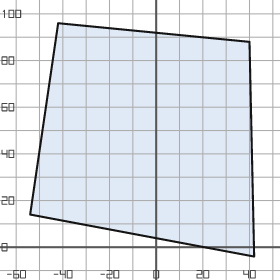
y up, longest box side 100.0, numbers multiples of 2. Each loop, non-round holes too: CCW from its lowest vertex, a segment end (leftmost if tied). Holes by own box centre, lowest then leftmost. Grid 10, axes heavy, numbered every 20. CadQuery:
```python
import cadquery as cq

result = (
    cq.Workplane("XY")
    .moveTo(42.0, -4.0)
    .lineTo(40.0, 88.0)
    .lineTo(-42.0, 96.0)
    .lineTo(-54.0, 14.0)
    .close()
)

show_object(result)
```